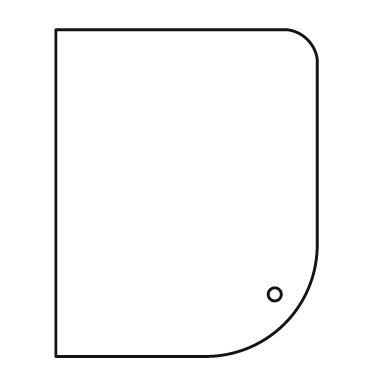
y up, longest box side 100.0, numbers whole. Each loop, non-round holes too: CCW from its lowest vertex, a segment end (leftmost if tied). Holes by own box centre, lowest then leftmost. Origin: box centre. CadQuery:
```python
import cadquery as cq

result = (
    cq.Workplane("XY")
    .moveTo(-40.0, -50.0)
    .lineTo(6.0, -50.0)
    .threePointArc((30.0, -40.0), (40.0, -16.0))
    .lineTo(40.0, 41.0)
    .threePointArc((37.0, 47.0), (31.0, 50.0))
    .lineTo(-40.0, 50.0)
    .close()
    .moveTo(27.0, -31.0)
    .circle(2.0)
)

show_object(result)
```